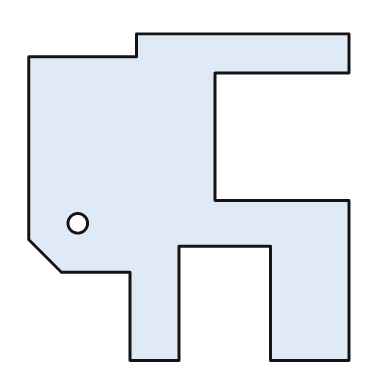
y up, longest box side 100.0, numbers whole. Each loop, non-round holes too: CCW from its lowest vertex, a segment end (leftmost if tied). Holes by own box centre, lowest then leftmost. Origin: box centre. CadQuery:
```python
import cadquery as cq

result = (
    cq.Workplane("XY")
    .moveTo(-18.0, -50.0)
    .lineTo(-3.0, -50.0)
    .lineTo(-3.0, -15.0)
    .lineTo(25.0, -15.0)
    .lineTo(25.0, -50.0)
    .lineTo(49.0, -50.0)
    .lineTo(49.0, -1.0)
    .lineTo(8.0, -1.0)
    .lineTo(8.0, 38.0)
    .lineTo(49.0, 38.0)
    .lineTo(49.0, 50.0)
    .lineTo(-16.0, 50.0)
    .lineTo(-16.0, 43.0)
    .lineTo(-49.0, 43.0)
    .lineTo(-49.0, -13.0)
    .lineTo(-39.0, -23.0)
    .lineTo(-18.0, -23.0)
    .close()
    .moveTo(-34.0, -8.0)
    .circle(3.0)
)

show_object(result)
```